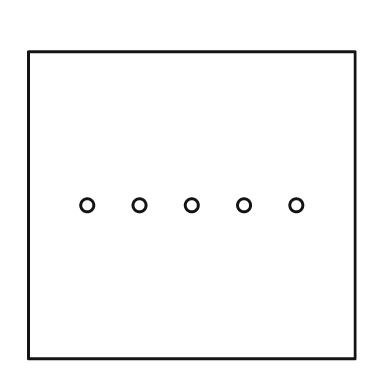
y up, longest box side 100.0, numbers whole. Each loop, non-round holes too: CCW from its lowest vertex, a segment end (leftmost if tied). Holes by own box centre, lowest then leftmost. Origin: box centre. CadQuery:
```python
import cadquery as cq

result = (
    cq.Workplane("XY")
    .moveTo(-50.0, -47.0)
    .lineTo(50.0, -47.0)
    .lineTo(50.0, 47.0)
    .lineTo(-50.0, 47.0)
    .close()
    .moveTo(-32.0, 0.0)
    .circle(2.0)
    .moveTo(-16.0, 0.0)
    .circle(2.0)
    .moveTo(0.0, 0.0)
    .circle(2.0)
    .moveTo(16.0, 0.0)
    .circle(2.0)
    .moveTo(32.0, 0.0)
    .circle(2.0)
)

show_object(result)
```